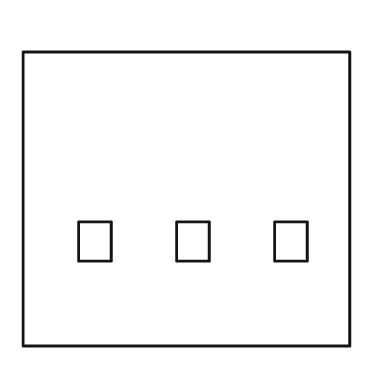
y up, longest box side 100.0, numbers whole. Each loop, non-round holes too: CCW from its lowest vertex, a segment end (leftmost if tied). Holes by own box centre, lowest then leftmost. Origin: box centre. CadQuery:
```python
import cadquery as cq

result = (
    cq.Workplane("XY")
    .moveTo(-50.0, -45.0)
    .lineTo(50.0, -45.0)
    .lineTo(50.0, 45.0)
    .lineTo(-50.0, 45.0)
    .close()
    .moveTo(-33.0, -19.0)
    .lineTo(-23.0, -19.0)
    .lineTo(-23.0, -7.0)
    .lineTo(-33.0, -7.0)
    .close()
    .moveTo(-3.0, -19.0)
    .lineTo(7.0, -19.0)
    .lineTo(7.0, -7.0)
    .lineTo(-3.0, -7.0)
    .close()
    .moveTo(27.0, -19.0)
    .lineTo(37.0, -19.0)
    .lineTo(37.0, -7.0)
    .lineTo(27.0, -7.0)
    .close()
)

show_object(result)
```